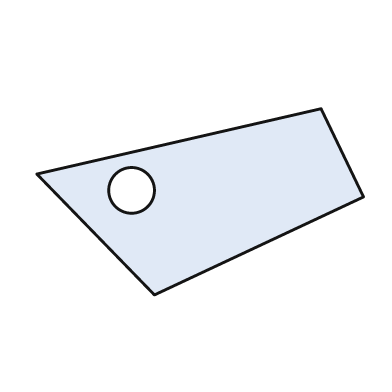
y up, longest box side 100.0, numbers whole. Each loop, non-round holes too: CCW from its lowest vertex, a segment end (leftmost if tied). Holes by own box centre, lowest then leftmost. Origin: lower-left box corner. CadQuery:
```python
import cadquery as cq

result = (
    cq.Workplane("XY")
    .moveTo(36.0, 0.0)
    .lineTo(100.0, 30.0)
    .lineTo(87.0, 57.0)
    .lineTo(0.0, 37.0)
    .close()
    .moveTo(29.0, 32.0)
    .circle(7.0)
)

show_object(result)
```